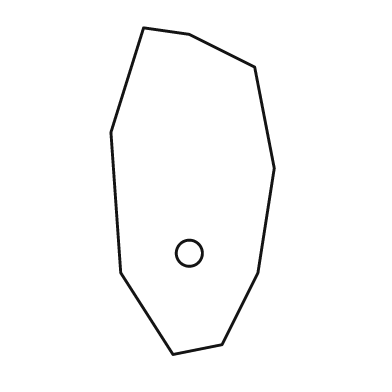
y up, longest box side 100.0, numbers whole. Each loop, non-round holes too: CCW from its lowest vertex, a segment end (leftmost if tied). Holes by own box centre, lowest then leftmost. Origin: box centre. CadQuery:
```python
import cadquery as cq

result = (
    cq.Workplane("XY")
    .moveTo(-6.0, -50.0)
    .lineTo(9.0, -47.0)
    .lineTo(20.0, -25.0)
    .lineTo(25.0, 7.0)
    .lineTo(19.0, 38.0)
    .lineTo(-1.0, 48.0)
    .lineTo(-15.0, 50.0)
    .lineTo(-25.0, 18.0)
    .lineTo(-22.0, -25.0)
    .close()
    .moveTo(-1.0, -19.0)
    .circle(4.0)
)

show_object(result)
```